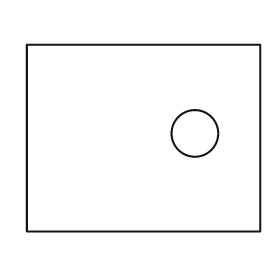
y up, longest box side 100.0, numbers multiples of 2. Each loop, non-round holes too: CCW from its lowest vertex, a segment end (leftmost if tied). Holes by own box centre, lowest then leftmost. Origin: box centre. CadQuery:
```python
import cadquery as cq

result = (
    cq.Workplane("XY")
    .moveTo(-50.0, -40.0)
    .lineTo(50.0, -40.0)
    .lineTo(50.0, 40.0)
    .lineTo(-50.0, 40.0)
    .close()
    .moveTo(22.0, 2.0)
    .circle(10.0)
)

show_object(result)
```